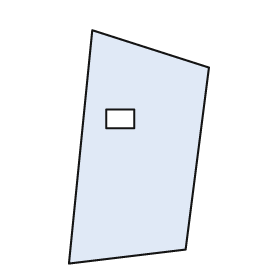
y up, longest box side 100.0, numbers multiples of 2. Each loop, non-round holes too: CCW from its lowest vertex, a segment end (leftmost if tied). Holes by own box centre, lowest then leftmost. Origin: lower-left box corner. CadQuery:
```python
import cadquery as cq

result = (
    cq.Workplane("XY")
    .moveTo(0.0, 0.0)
    .lineTo(50.0, 6.0)
    .lineTo(60.0, 84.0)
    .lineTo(10.0, 100.0)
    .close()
    .moveTo(16.0, 58.0)
    .lineTo(28.0, 58.0)
    .lineTo(28.0, 66.0)
    .lineTo(16.0, 66.0)
    .close()
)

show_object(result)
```